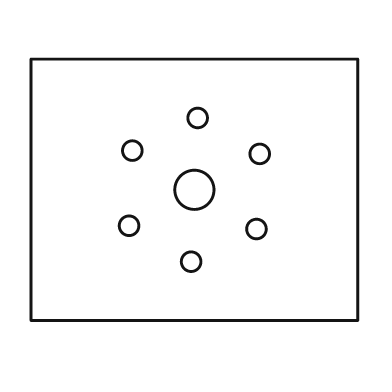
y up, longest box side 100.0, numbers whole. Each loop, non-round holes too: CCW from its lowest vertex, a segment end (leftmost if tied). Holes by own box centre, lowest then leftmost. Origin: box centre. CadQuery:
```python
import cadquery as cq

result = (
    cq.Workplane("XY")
    .moveTo(-50.0, -40.0)
    .lineTo(50.0, -40.0)
    .lineTo(50.0, 40.0)
    .lineTo(-50.0, 40.0)
    .close()
    .moveTo(-1.0, -22.0)
    .circle(3.0)
    .moveTo(19.0, -12.0)
    .circle(3.0)
    .moveTo(-20.0, -11.0)
    .circle(3.0)
    .moveTo(0.0, 0.0)
    .circle(6.0)
    .moveTo(20.0, 11.0)
    .circle(3.0)
    .moveTo(-19.0, 12.0)
    .circle(3.0)
    .moveTo(1.0, 22.0)
    .circle(3.0)
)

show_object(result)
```